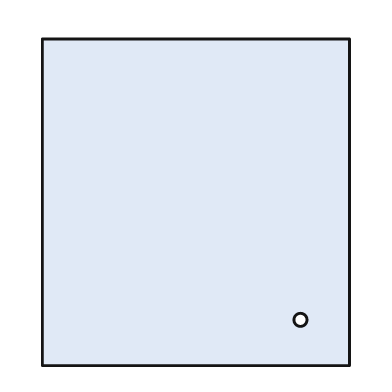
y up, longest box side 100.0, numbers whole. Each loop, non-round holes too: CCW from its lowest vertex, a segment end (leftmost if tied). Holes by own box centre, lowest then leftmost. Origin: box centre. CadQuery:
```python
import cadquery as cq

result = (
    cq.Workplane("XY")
    .moveTo(-47.0, -50.0)
    .lineTo(47.0, -50.0)
    .lineTo(47.0, 50.0)
    .lineTo(-47.0, 50.0)
    .close()
    .moveTo(32.0, -36.0)
    .circle(2.0)
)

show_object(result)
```